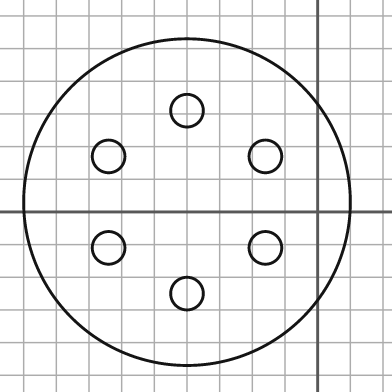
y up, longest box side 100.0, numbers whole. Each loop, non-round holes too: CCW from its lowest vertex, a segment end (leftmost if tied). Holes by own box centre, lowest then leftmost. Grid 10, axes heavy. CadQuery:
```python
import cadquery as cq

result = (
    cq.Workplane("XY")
    .moveTo(-40.0, 3.0)
    .circle(50.0)
    .moveTo(-40.0, -25.0)
    .circle(5.0)
    .moveTo(-64.0, -11.0)
    .circle(5.0)
    .moveTo(-16.0, -11.0)
    .circle(5.0)
    .moveTo(-64.0, 17.0)
    .circle(5.0)
    .moveTo(-16.0, 17.0)
    .circle(5.0)
    .moveTo(-40.0, 31.0)
    .circle(5.0)
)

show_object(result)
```